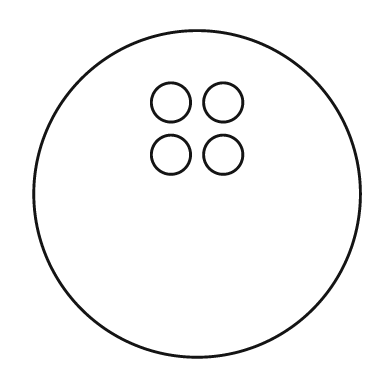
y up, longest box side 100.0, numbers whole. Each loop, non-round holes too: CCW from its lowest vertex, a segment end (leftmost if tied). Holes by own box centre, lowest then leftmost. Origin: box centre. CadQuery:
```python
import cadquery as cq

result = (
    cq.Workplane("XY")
    .moveTo(0.0, 0.0)
    .circle(50.0)
    .moveTo(-8.0, 12.0)
    .circle(6.0)
    .moveTo(8.0, 12.0)
    .circle(6.0)
    .moveTo(-8.0, 28.0)
    .circle(6.0)
    .moveTo(8.0, 28.0)
    .circle(6.0)
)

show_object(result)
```